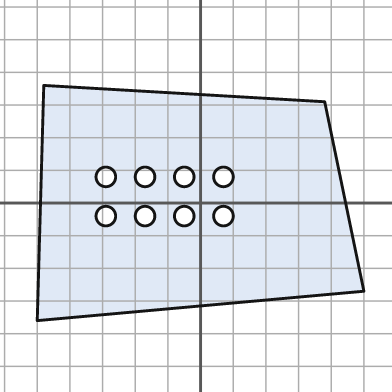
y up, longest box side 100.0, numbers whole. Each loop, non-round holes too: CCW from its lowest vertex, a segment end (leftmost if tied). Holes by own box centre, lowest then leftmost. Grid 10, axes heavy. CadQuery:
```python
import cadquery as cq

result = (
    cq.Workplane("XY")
    .moveTo(-50.0, -36.0)
    .lineTo(50.0, -27.0)
    .lineTo(38.0, 31.0)
    .lineTo(-48.0, 36.0)
    .close()
    .moveTo(-29.0, -4.0)
    .circle(3.0)
    .moveTo(-17.0, -4.0)
    .circle(3.0)
    .moveTo(-5.0, -4.0)
    .circle(3.0)
    .moveTo(7.0, -4.0)
    .circle(3.0)
    .moveTo(-29.0, 8.0)
    .circle(3.0)
    .moveTo(-17.0, 8.0)
    .circle(3.0)
    .moveTo(-5.0, 8.0)
    .circle(3.0)
    .moveTo(7.0, 8.0)
    .circle(3.0)
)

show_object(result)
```